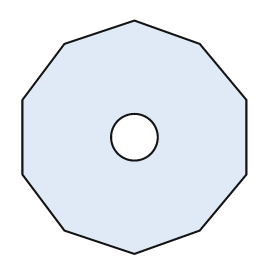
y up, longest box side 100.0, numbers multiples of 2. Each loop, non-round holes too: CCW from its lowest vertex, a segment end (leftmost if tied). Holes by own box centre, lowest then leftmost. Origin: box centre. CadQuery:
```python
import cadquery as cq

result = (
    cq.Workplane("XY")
    .moveTo(0.0, -50.0)
    .lineTo(28.0, -40.0)
    .lineTo(48.0, -16.0)
    .lineTo(48.0, 16.0)
    .lineTo(28.0, 40.0)
    .lineTo(0.0, 50.0)
    .lineTo(-30.0, 40.0)
    .lineTo(-48.0, 16.0)
    .lineTo(-48.0, -16.0)
    .lineTo(-30.0, -40.0)
    .close()
    .moveTo(0.0, 0.0)
    .circle(10.0)
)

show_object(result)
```